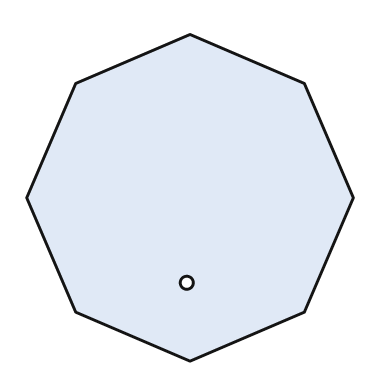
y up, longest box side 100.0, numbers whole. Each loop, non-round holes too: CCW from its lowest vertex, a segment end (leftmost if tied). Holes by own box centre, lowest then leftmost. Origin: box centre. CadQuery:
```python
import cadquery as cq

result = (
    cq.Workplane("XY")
    .moveTo(0.0, -50.0)
    .lineTo(35.0, -35.0)
    .lineTo(50.0, 0.0)
    .lineTo(35.0, 35.0)
    .lineTo(0.0, 50.0)
    .lineTo(-35.0, 35.0)
    .lineTo(-50.0, 0.0)
    .lineTo(-35.0, -35.0)
    .close()
    .moveTo(-1.0, -26.0)
    .circle(2.0)
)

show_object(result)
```